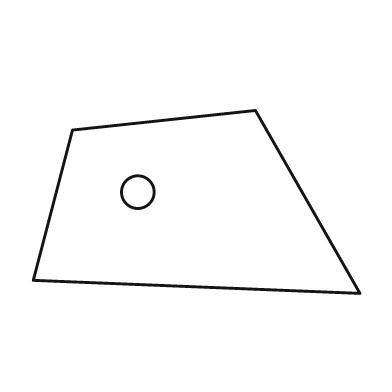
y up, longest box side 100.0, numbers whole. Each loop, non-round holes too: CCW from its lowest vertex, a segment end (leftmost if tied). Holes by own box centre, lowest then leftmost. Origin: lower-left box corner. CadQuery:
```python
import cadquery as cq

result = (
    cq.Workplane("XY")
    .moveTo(100.0, 0.0)
    .lineTo(68.0, 56.0)
    .lineTo(12.0, 50.0)
    .lineTo(0.0, 4.0)
    .close()
    .moveTo(32.0, 31.0)
    .circle(5.0)
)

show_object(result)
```